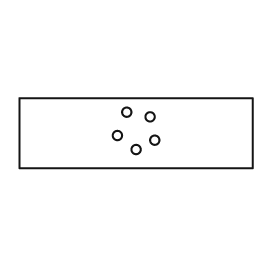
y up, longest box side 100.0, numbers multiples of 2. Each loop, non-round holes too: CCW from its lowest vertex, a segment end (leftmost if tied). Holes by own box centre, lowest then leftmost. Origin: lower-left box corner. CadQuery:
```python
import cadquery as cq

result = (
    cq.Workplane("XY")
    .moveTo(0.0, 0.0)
    .lineTo(100.0, 0.0)
    .lineTo(100.0, 30.0)
    .lineTo(0.0, 30.0)
    .close()
    .moveTo(50.0, 8.0)
    .circle(2.0)
    .moveTo(58.0, 12.0)
    .circle(2.0)
    .moveTo(42.0, 14.0)
    .circle(2.0)
    .moveTo(56.0, 22.0)
    .circle(2.0)
    .moveTo(46.0, 24.0)
    .circle(2.0)
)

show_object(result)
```